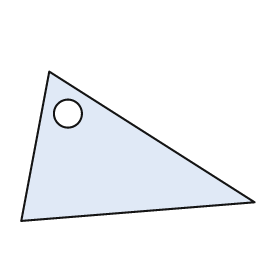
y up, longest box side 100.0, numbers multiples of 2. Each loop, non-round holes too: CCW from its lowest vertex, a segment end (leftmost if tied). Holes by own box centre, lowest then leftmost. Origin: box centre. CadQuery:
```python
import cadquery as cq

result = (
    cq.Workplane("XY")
    .moveTo(-50.0, -32.0)
    .lineTo(50.0, -24.0)
    .lineTo(-38.0, 32.0)
    .close()
    .moveTo(-30.0, 14.0)
    .circle(6.0)
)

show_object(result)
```